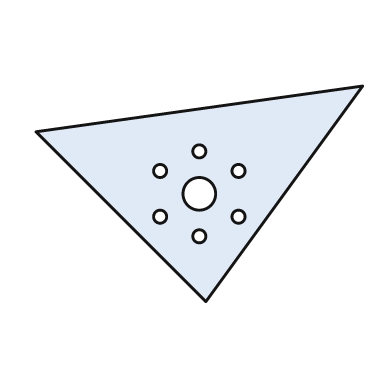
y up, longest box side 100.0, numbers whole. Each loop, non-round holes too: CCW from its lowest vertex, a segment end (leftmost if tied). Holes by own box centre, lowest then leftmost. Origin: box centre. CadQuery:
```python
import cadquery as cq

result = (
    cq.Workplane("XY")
    .moveTo(2.0, -33.0)
    .lineTo(50.0, 33.0)
    .lineTo(-50.0, 19.0)
    .close()
    .moveTo(0.0, -13.0)
    .circle(2.0)
    .moveTo(-12.0, -7.0)
    .circle(2.0)
    .moveTo(12.0, -7.0)
    .circle(2.0)
    .moveTo(0.0, 0.0)
    .circle(5.0)
    .moveTo(-12.0, 7.0)
    .circle(2.0)
    .moveTo(12.0, 7.0)
    .circle(2.0)
    .moveTo(0.0, 13.0)
    .circle(2.0)
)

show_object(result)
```